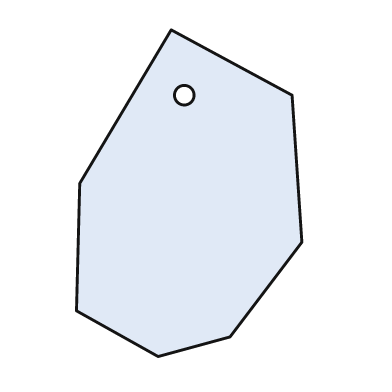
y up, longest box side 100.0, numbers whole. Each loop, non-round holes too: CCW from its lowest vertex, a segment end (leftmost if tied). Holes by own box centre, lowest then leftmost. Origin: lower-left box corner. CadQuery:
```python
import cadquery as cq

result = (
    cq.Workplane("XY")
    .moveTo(25.0, 0.0)
    .lineTo(47.0, 6.0)
    .lineTo(69.0, 35.0)
    .lineTo(66.0, 80.0)
    .lineTo(29.0, 100.0)
    .lineTo(1.0, 53.0)
    .lineTo(0.0, 14.0)
    .close()
    .moveTo(33.0, 80.0)
    .circle(3.0)
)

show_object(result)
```